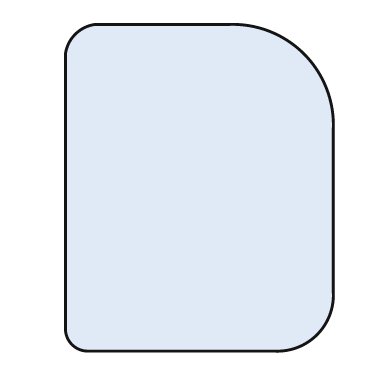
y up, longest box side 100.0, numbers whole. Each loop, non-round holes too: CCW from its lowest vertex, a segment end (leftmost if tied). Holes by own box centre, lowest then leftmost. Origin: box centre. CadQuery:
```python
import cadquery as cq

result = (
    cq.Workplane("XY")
    .moveTo(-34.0, -50.0)
    .lineTo(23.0, -50.0)
    .threePointArc((36.0, -45.0), (41.0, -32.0))
    .lineTo(41.0, 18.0)
    .threePointArc((32.0, 41.0), (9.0, 50.0))
    .lineTo(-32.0, 50.0)
    .threePointArc((-38.0, 47.0), (-41.0, 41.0))
    .lineTo(-41.0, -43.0)
    .threePointArc((-39.0, -48.0), (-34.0, -50.0))
    .close()
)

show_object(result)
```